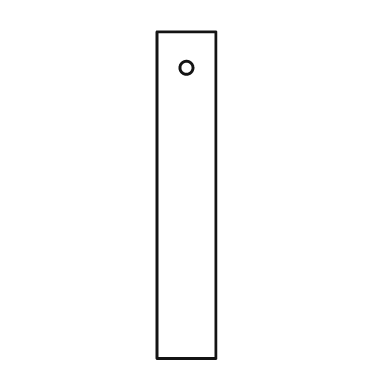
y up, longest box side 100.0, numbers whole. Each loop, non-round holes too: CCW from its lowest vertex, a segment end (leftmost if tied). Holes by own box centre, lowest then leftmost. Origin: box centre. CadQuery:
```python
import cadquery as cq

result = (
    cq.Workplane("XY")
    .moveTo(-9.0, -50.0)
    .lineTo(9.0, -50.0)
    .lineTo(9.0, 50.0)
    .lineTo(-9.0, 50.0)
    .close()
    .moveTo(0.0, 39.0)
    .circle(2.0)
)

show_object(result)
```